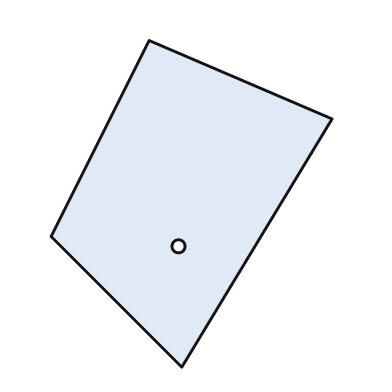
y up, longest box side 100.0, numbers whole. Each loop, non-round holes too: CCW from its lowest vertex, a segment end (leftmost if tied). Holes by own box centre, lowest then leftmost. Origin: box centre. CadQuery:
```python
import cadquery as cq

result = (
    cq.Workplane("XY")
    .moveTo(-3.0, -50.0)
    .lineTo(43.0, 26.0)
    .lineTo(-13.0, 50.0)
    .lineTo(-43.0, -10.0)
    .close()
    .moveTo(-4.0, -13.0)
    .circle(2.0)
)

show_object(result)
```